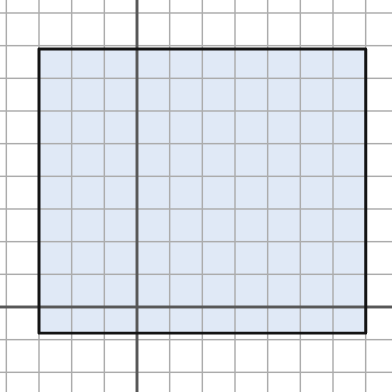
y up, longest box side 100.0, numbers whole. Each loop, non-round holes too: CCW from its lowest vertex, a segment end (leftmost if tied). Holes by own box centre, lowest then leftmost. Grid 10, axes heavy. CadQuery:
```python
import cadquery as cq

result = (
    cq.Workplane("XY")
    .moveTo(-30.0, -8.0)
    .lineTo(70.0, -8.0)
    .lineTo(70.0, 79.0)
    .lineTo(-30.0, 79.0)
    .close()
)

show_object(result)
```